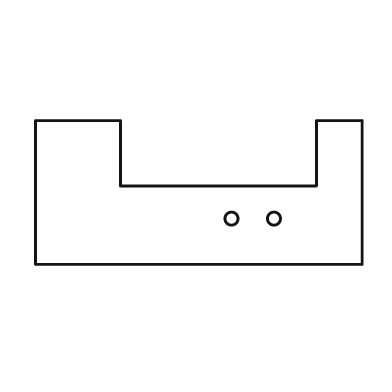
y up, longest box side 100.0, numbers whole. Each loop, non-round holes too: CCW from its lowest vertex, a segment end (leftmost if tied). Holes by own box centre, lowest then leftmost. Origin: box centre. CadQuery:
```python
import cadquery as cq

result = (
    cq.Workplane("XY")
    .moveTo(-50.0, -22.0)
    .lineTo(50.0, -22.0)
    .lineTo(50.0, 22.0)
    .lineTo(36.0, 22.0)
    .lineTo(36.0, 2.0)
    .lineTo(-24.0, 2.0)
    .lineTo(-24.0, 22.0)
    .lineTo(-50.0, 22.0)
    .close()
    .moveTo(10.0, -8.0)
    .circle(2.0)
    .moveTo(23.0, -8.0)
    .circle(2.0)
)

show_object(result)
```